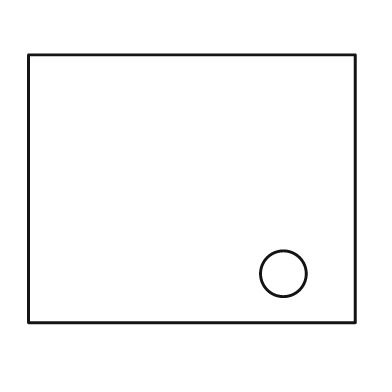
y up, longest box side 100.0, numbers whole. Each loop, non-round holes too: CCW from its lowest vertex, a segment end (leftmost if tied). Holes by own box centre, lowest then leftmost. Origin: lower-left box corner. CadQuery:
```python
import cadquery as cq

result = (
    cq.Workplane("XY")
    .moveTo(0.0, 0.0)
    .lineTo(100.0, 0.0)
    .lineTo(100.0, 82.0)
    .lineTo(0.0, 82.0)
    .close()
    .moveTo(78.0, 15.0)
    .circle(7.0)
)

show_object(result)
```